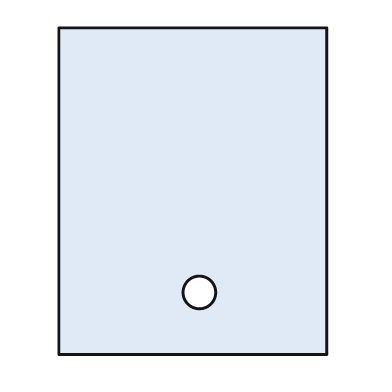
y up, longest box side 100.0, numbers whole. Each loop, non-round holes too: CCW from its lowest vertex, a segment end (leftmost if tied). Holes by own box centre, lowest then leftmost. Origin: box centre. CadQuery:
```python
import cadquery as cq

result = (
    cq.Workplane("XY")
    .moveTo(-41.0, -50.0)
    .lineTo(41.0, -50.0)
    .lineTo(41.0, 50.0)
    .lineTo(-41.0, 50.0)
    .close()
    .moveTo(2.0, -31.0)
    .circle(5.0)
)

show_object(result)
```